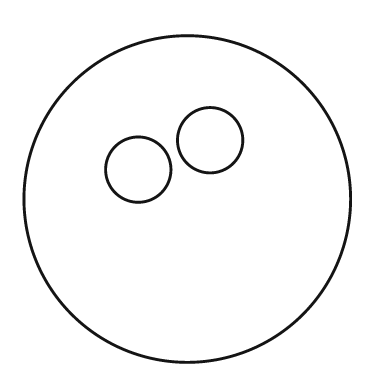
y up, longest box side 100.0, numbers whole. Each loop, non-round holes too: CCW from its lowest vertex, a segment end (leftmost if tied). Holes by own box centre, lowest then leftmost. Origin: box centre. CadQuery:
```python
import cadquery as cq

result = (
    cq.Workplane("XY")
    .moveTo(0.0, 0.0)
    .circle(50.0)
    .moveTo(-15.0, 9.0)
    .circle(10.0)
    .moveTo(7.0, 18.0)
    .circle(10.0)
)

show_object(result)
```